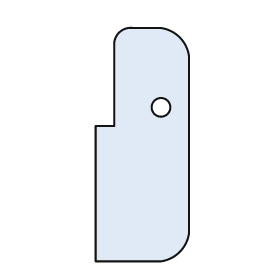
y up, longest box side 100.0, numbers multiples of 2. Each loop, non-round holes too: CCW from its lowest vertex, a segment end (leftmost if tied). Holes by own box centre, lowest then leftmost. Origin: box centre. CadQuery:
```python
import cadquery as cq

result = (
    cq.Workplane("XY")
    .moveTo(-20.0, -50.0)
    .lineTo(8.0, -50.0)
    .threePointArc((16.0, -46.0), (20.0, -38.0))
    .lineTo(20.0, 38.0)
    .threePointArc((16.0, 46.0), (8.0, 50.0))
    .lineTo(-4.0, 50.0)
    .threePointArc((-10.0, 48.0), (-12.0, 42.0))
    .lineTo(-12.0, 8.0)
    .lineTo(-20.0, 8.0)
    .close()
    .moveTo(8.0, 16.0)
    .circle(4.0)
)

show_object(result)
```